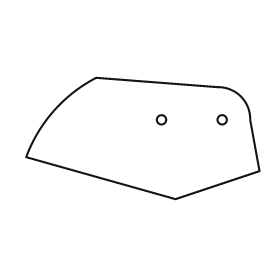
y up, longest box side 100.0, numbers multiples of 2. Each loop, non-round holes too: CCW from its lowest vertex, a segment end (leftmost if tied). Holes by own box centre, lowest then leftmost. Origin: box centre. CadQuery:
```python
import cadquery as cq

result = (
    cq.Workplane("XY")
    .moveTo(14.0, -26.0)
    .lineTo(50.0, -14.0)
    .lineTo(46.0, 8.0)
    .threePointArc((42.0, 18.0), (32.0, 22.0))
    .lineTo(-20.0, 26.0)
    .threePointArc((-38.0, 12.0), (-50.0, -8.0))
    .close()
    .moveTo(8.0, 8.0)
    .circle(2.0)
    .moveTo(34.0, 8.0)
    .circle(2.0)
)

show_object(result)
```